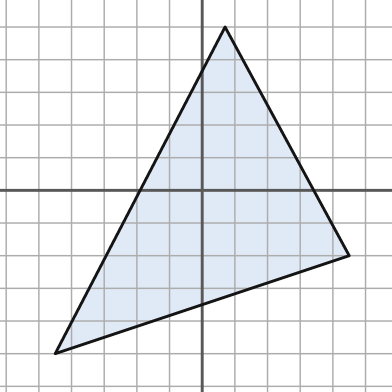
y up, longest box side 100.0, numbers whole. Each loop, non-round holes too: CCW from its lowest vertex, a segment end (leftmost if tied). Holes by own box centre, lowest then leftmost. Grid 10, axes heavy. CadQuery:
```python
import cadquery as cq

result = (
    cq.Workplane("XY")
    .moveTo(-45.0, -50.0)
    .lineTo(45.0, -20.0)
    .lineTo(7.0, 50.0)
    .close()
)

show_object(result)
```